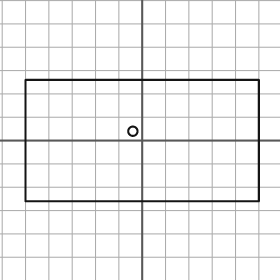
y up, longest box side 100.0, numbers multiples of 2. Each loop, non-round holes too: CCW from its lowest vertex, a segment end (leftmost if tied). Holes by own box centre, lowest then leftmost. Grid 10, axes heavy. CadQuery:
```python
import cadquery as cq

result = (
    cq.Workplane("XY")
    .moveTo(-50.0, -26.0)
    .lineTo(50.0, -26.0)
    .lineTo(50.0, 26.0)
    .lineTo(-50.0, 26.0)
    .close()
    .moveTo(-4.0, 4.0)
    .circle(2.0)
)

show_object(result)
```